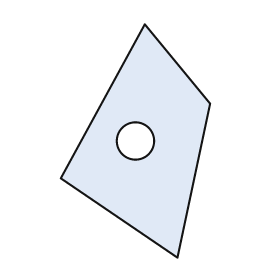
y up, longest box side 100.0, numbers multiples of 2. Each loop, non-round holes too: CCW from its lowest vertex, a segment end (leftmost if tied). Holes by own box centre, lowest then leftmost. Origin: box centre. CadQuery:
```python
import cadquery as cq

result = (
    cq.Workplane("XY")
    .moveTo(18.0, -50.0)
    .lineTo(32.0, 16.0)
    .lineTo(4.0, 50.0)
    .lineTo(-32.0, -16.0)
    .close()
    .moveTo(0.0, 0.0)
    .circle(8.0)
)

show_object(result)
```